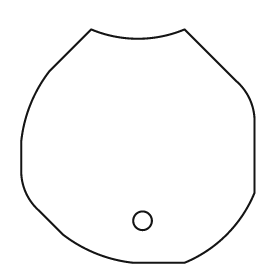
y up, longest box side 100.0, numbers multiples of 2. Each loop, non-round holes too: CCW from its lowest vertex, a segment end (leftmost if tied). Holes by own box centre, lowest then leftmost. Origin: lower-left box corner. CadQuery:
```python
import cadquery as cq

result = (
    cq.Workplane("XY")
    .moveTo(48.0, 0.0)
    .lineTo(70.0, 0.0)
    .threePointArc((88.0, 12.0), (100.0, 30.0))
    .lineTo(100.0, 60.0)
    .threePointArc((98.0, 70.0), (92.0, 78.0))
    .lineTo(70.0, 100.0)
    .threePointArc((50.0, 96.0), (30.0, 100.0))
    .lineTo(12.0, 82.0)
    .threePointArc((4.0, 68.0), (0.0, 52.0))
    .lineTo(0.0, 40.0)
    .threePointArc((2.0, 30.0), (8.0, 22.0))
    .lineTo(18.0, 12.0)
    .threePointArc((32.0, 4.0), (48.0, 0.0))
    .close()
    .moveTo(52.0, 18.0)
    .circle(4.0)
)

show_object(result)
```